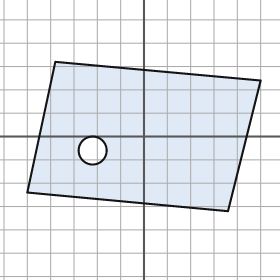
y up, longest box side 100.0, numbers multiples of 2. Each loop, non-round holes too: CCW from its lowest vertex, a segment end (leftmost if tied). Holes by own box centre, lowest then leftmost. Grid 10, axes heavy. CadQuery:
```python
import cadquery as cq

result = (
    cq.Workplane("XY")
    .moveTo(36.0, -32.0)
    .lineTo(50.0, 24.0)
    .lineTo(-38.0, 32.0)
    .lineTo(-50.0, -24.0)
    .close()
    .moveTo(-22.0, -6.0)
    .circle(6.0)
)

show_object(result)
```